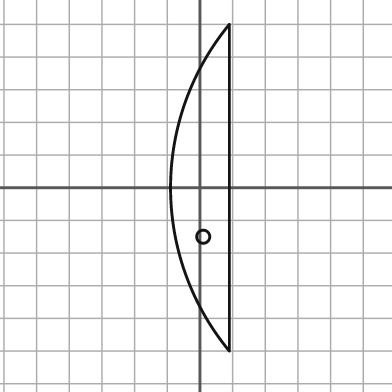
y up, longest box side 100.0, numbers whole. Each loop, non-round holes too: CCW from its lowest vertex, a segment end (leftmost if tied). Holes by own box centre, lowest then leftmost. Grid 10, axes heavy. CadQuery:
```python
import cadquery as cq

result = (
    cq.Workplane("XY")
    .moveTo(9.0, -50.0)
    .lineTo(9.0, 50.0)
    .threePointArc((-9.0, 0.0), (9.0, -50.0))
    .close()
    .moveTo(1.0, -15.0)
    .circle(2.0)
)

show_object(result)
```